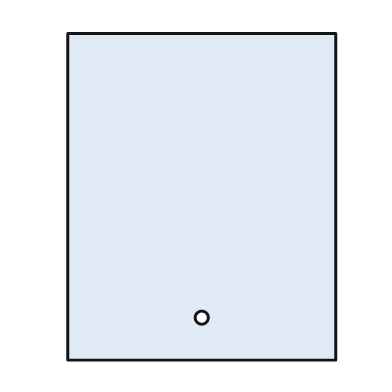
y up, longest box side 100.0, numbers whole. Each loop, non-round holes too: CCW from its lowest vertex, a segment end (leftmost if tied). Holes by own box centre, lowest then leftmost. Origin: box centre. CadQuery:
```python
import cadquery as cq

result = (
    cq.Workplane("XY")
    .moveTo(-41.0, -50.0)
    .lineTo(41.0, -50.0)
    .lineTo(41.0, 50.0)
    .lineTo(-41.0, 50.0)
    .close()
    .moveTo(0.0, -37.0)
    .circle(2.0)
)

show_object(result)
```